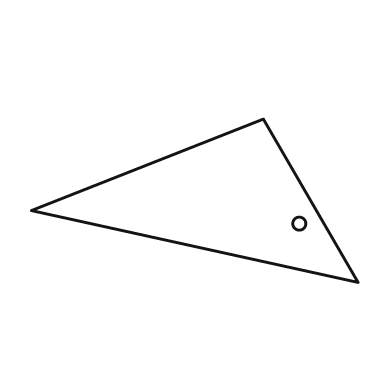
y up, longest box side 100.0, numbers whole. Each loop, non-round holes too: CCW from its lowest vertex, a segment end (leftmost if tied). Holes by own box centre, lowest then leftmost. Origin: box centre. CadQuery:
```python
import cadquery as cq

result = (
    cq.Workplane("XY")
    .moveTo(50.0, -25.0)
    .lineTo(21.0, 25.0)
    .lineTo(-50.0, -3.0)
    .close()
    .moveTo(32.0, -7.0)
    .circle(2.0)
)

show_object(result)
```